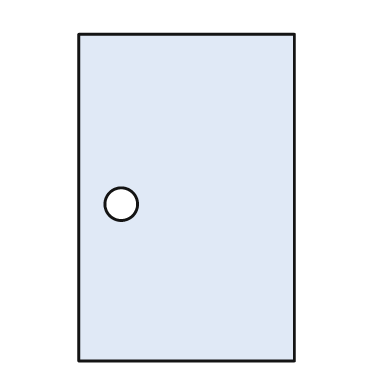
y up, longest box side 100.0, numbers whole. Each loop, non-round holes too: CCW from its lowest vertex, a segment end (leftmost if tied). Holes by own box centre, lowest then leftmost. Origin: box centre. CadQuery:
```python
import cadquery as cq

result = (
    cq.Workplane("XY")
    .moveTo(-33.0, -50.0)
    .lineTo(33.0, -50.0)
    .lineTo(33.0, 50.0)
    .lineTo(-33.0, 50.0)
    .close()
    .moveTo(-20.0, -2.0)
    .circle(5.0)
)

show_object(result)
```